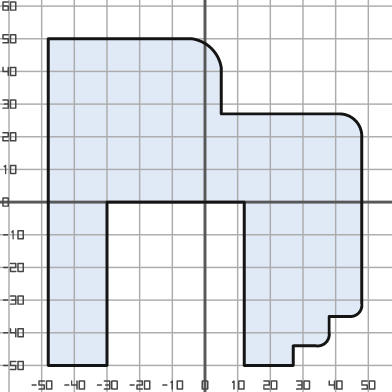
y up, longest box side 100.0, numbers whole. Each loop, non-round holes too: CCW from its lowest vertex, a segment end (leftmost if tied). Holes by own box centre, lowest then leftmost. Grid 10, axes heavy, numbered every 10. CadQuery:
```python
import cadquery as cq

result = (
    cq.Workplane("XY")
    .moveTo(-48.0, -50.0)
    .lineTo(-30.0, -50.0)
    .lineTo(-30.0, 0.0)
    .lineTo(12.0, 0.0)
    .lineTo(12.0, -50.0)
    .lineTo(27.0, -50.0)
    .lineTo(27.0, -44.0)
    .lineTo(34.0, -44.0)
    .threePointArc((37.0, -43.0), (38.0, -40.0))
    .lineTo(38.0, -35.0)
    .lineTo(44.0, -35.0)
    .threePointArc((47.0, -34.0), (48.0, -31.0))
    .lineTo(48.0, 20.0)
    .threePointArc((46.0, 25.0), (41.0, 27.0))
    .lineTo(5.0, 27.0)
    .lineTo(5.0, 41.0)
    .threePointArc((2.0, 47.0), (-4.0, 50.0))
    .lineTo(-48.0, 50.0)
    .close()
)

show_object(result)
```